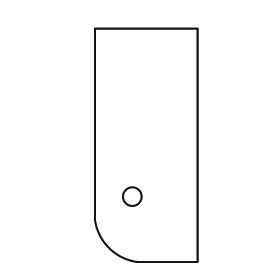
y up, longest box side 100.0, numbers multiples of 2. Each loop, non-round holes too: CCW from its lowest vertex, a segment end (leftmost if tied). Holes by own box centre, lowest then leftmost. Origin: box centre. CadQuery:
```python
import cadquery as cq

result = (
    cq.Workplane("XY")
    .moveTo(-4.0, -50.0)
    .lineTo(22.0, -50.0)
    .lineTo(22.0, 50.0)
    .lineTo(-22.0, 50.0)
    .lineTo(-22.0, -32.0)
    .threePointArc((-16.0, -44.0), (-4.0, -50.0))
    .close()
    .moveTo(-6.0, -22.0)
    .circle(4.0)
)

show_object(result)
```